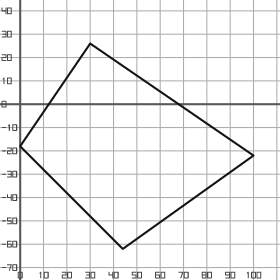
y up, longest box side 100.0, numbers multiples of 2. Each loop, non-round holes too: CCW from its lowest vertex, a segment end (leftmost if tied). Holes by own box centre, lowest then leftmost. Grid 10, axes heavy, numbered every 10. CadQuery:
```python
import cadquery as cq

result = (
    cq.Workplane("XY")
    .moveTo(44.0, -62.0)
    .lineTo(100.0, -22.0)
    .lineTo(30.0, 26.0)
    .lineTo(0.0, -18.0)
    .close()
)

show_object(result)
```